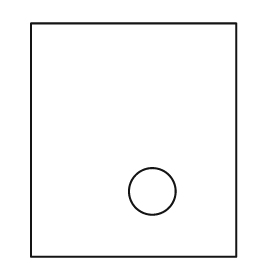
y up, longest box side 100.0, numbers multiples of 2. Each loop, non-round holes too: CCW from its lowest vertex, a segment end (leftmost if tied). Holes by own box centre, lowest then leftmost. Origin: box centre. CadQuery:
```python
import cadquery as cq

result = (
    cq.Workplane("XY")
    .moveTo(-44.0, -50.0)
    .lineTo(44.0, -50.0)
    .lineTo(44.0, 50.0)
    .lineTo(-44.0, 50.0)
    .close()
    .moveTo(8.0, -22.0)
    .circle(10.0)
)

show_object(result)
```